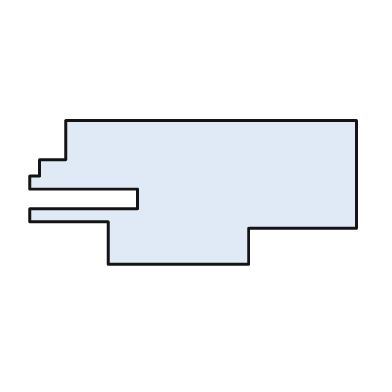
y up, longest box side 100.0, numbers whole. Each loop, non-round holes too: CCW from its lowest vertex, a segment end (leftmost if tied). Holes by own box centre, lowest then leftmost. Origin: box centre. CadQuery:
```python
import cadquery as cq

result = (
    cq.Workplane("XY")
    .moveTo(-26.0, -22.0)
    .lineTo(17.0, -22.0)
    .lineTo(17.0, -11.0)
    .lineTo(50.0, -11.0)
    .lineTo(50.0, 22.0)
    .lineTo(-39.0, 22.0)
    .lineTo(-39.0, 10.0)
    .lineTo(-47.0, 10.0)
    .lineTo(-47.0, 5.0)
    .lineTo(-50.0, 5.0)
    .lineTo(-50.0, 1.0)
    .lineTo(-17.0, 1.0)
    .lineTo(-17.0, -5.0)
    .lineTo(-50.0, -5.0)
    .lineTo(-50.0, -9.0)
    .lineTo(-26.0, -9.0)
    .close()
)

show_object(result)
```